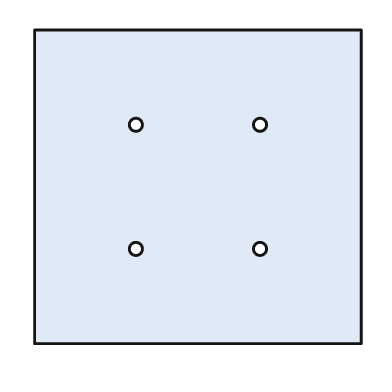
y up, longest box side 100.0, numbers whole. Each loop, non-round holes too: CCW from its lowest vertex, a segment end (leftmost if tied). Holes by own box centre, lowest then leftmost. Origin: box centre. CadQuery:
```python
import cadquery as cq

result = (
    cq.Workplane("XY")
    .moveTo(-50.0, -48.0)
    .lineTo(50.0, -48.0)
    .lineTo(50.0, 48.0)
    .lineTo(-50.0, 48.0)
    .close()
    .moveTo(-19.0, -19.0)
    .circle(2.0)
    .moveTo(19.0, -19.0)
    .circle(2.0)
    .moveTo(-19.0, 19.0)
    .circle(2.0)
    .moveTo(19.0, 19.0)
    .circle(2.0)
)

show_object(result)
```